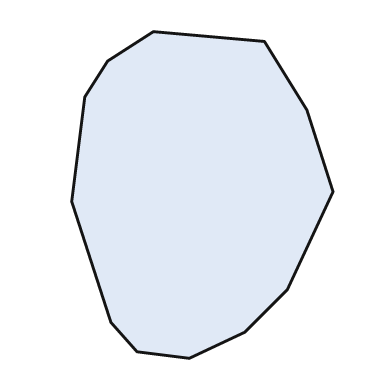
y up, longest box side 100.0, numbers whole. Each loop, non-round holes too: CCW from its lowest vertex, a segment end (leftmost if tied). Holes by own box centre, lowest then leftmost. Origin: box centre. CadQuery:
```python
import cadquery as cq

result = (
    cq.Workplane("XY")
    .moveTo(-4.0, -50.0)
    .lineTo(13.0, -42.0)
    .lineTo(26.0, -29.0)
    .lineTo(40.0, 1.0)
    .lineTo(32.0, 26.0)
    .lineTo(19.0, 47.0)
    .lineTo(-15.0, 50.0)
    .lineTo(-29.0, 41.0)
    .lineTo(-36.0, 30.0)
    .lineTo(-40.0, -2.0)
    .lineTo(-28.0, -39.0)
    .lineTo(-20.0, -48.0)
    .close()
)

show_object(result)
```